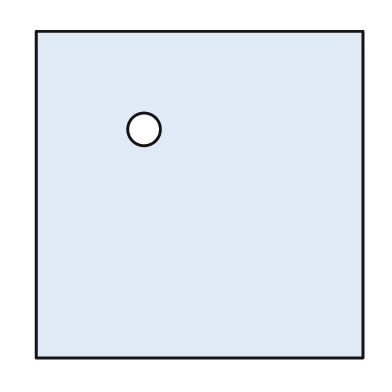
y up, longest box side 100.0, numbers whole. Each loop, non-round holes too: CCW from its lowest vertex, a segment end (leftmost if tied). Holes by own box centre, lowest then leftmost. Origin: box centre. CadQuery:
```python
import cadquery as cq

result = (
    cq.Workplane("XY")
    .moveTo(-50.0, -50.0)
    .lineTo(50.0, -50.0)
    .lineTo(50.0, 50.0)
    .lineTo(-50.0, 50.0)
    .close()
    .moveTo(-17.0, 20.0)
    .circle(5.0)
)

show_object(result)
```